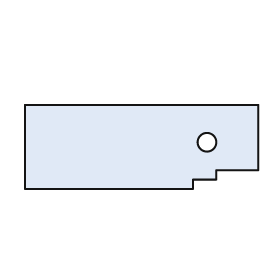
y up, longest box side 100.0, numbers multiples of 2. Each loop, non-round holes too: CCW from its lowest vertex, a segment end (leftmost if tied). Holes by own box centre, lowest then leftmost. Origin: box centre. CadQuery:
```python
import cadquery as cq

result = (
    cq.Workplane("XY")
    .moveTo(-50.0, -18.0)
    .lineTo(22.0, -18.0)
    .lineTo(22.0, -14.0)
    .lineTo(32.0, -14.0)
    .lineTo(32.0, -10.0)
    .lineTo(50.0, -10.0)
    .lineTo(50.0, 18.0)
    .lineTo(-50.0, 18.0)
    .close()
    .moveTo(28.0, 2.0)
    .circle(4.0)
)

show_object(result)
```